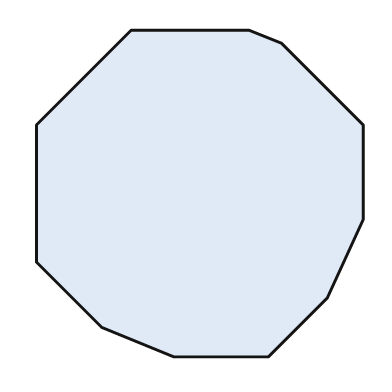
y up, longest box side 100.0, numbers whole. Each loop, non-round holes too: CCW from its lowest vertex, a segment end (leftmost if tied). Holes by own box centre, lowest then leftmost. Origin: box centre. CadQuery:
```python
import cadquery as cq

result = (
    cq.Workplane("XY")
    .moveTo(-8.0, -50.0)
    .lineTo(21.0, -50.0)
    .lineTo(39.0, -32.0)
    .lineTo(50.0, -8.0)
    .lineTo(50.0, 21.0)
    .lineTo(25.0, 46.0)
    .lineTo(15.0, 50.0)
    .lineTo(-21.0, 50.0)
    .lineTo(-50.0, 21.0)
    .lineTo(-50.0, -21.0)
    .lineTo(-30.0, -41.0)
    .close()
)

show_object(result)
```